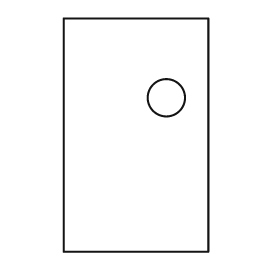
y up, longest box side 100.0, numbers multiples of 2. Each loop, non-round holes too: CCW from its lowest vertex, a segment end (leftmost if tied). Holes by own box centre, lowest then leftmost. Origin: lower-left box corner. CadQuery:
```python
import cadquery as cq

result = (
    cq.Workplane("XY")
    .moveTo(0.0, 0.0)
    .lineTo(62.0, 0.0)
    .lineTo(62.0, 100.0)
    .lineTo(0.0, 100.0)
    .close()
    .moveTo(44.0, 66.0)
    .circle(8.0)
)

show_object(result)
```